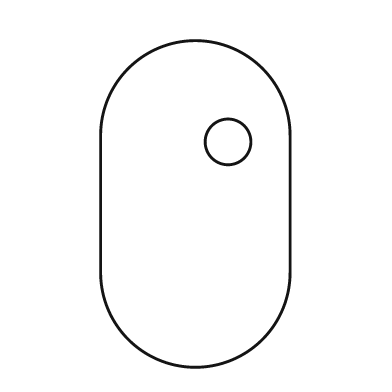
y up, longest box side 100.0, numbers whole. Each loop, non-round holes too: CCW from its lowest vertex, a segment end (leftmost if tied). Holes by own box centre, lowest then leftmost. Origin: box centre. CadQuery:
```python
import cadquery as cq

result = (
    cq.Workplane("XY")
    .moveTo(-29.0, -21.0)
    .threePointArc((0.0, -50.0), (29.0, -21.0))
    .lineTo(29.0, 21.0)
    .threePointArc((0.0, 50.0), (-29.0, 21.0))
    .close()
    .moveTo(10.0, 19.0)
    .circle(7.0)
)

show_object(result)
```